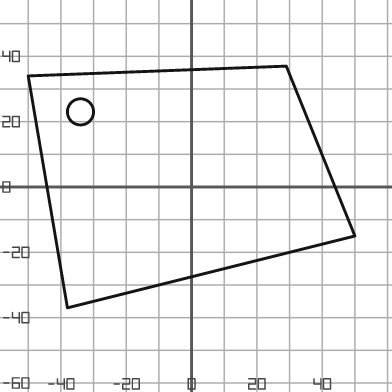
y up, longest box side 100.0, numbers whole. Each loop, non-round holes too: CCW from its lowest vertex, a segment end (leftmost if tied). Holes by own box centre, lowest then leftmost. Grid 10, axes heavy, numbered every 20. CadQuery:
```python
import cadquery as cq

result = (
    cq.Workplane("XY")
    .moveTo(-38.0, -37.0)
    .lineTo(50.0, -15.0)
    .lineTo(29.0, 37.0)
    .lineTo(-50.0, 34.0)
    .close()
    .moveTo(-34.0, 23.0)
    .circle(4.0)
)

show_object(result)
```